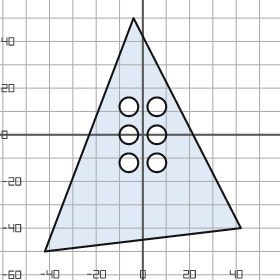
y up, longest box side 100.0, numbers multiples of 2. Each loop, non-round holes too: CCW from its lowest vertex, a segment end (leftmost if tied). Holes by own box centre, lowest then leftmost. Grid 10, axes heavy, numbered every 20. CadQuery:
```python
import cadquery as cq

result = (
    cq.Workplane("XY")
    .moveTo(-42.0, -50.0)
    .lineTo(42.0, -40.0)
    .lineTo(-4.0, 50.0)
    .close()
    .moveTo(-6.0, -12.0)
    .circle(4.0)
    .moveTo(6.0, -12.0)
    .circle(4.0)
    .moveTo(-6.0, 0.0)
    .circle(4.0)
    .moveTo(6.0, 0.0)
    .circle(4.0)
    .moveTo(-6.0, 12.0)
    .circle(4.0)
    .moveTo(6.0, 12.0)
    .circle(4.0)
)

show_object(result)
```